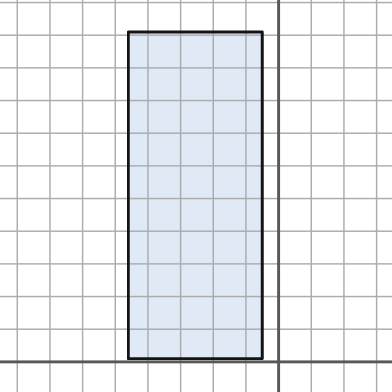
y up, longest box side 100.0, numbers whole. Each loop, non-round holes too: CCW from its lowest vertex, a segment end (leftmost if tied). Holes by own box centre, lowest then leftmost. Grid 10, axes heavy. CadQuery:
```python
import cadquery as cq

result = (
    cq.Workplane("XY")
    .moveTo(-46.0, 1.0)
    .lineTo(-5.0, 1.0)
    .lineTo(-5.0, 101.0)
    .lineTo(-46.0, 101.0)
    .close()
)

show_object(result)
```